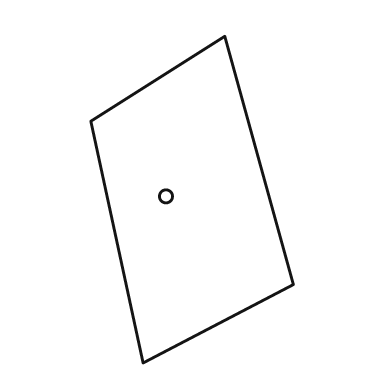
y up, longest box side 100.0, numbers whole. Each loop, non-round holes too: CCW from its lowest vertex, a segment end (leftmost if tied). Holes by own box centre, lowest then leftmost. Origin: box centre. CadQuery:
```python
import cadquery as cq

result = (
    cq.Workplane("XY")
    .moveTo(-15.0, -50.0)
    .lineTo(31.0, -26.0)
    .lineTo(10.0, 50.0)
    .lineTo(-31.0, 24.0)
    .close()
    .moveTo(-8.0, 1.0)
    .circle(2.0)
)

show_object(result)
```